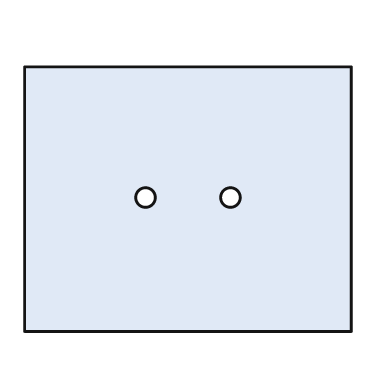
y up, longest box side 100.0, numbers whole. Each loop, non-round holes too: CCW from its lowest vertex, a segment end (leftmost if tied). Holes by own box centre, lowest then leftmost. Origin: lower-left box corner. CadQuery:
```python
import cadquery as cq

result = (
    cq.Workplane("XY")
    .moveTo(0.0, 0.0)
    .lineTo(100.0, 0.0)
    .lineTo(100.0, 81.0)
    .lineTo(0.0, 81.0)
    .close()
    .moveTo(37.0, 41.0)
    .circle(3.0)
    .moveTo(63.0, 41.0)
    .circle(3.0)
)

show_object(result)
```